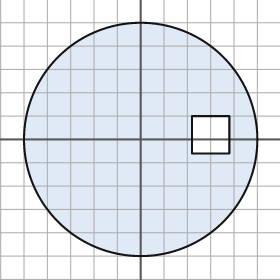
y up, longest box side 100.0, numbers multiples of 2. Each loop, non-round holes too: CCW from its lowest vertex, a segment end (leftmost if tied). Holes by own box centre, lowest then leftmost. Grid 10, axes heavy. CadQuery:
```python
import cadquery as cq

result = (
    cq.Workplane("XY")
    .moveTo(0.0, 0.0)
    .circle(50.0)
    .moveTo(22.0, -6.0)
    .lineTo(38.0, -6.0)
    .lineTo(38.0, 10.0)
    .lineTo(22.0, 10.0)
    .close()
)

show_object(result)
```